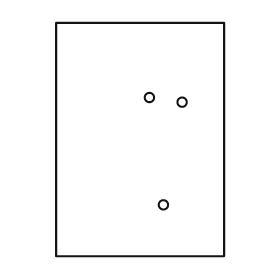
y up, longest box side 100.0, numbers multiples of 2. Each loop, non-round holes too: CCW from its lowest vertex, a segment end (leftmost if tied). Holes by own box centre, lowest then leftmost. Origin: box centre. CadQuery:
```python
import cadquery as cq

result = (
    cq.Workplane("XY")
    .moveTo(-36.0, -50.0)
    .lineTo(36.0, -50.0)
    .lineTo(36.0, 50.0)
    .lineTo(-36.0, 50.0)
    .close()
    .moveTo(10.0, -28.0)
    .circle(2.0)
    .moveTo(18.0, 16.0)
    .circle(2.0)
    .moveTo(4.0, 18.0)
    .circle(2.0)
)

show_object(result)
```